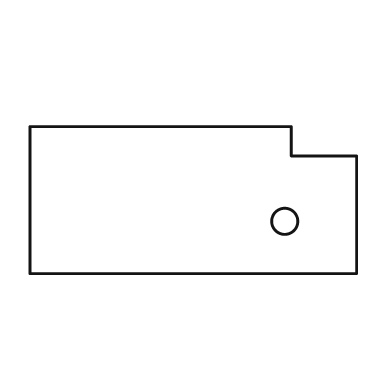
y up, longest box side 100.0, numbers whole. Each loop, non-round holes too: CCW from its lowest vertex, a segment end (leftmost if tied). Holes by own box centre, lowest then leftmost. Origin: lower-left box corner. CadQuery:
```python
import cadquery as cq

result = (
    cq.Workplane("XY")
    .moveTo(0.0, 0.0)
    .lineTo(100.0, 0.0)
    .lineTo(100.0, 36.0)
    .lineTo(80.0, 36.0)
    .lineTo(80.0, 45.0)
    .lineTo(0.0, 45.0)
    .close()
    .moveTo(78.0, 16.0)
    .circle(4.0)
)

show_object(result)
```